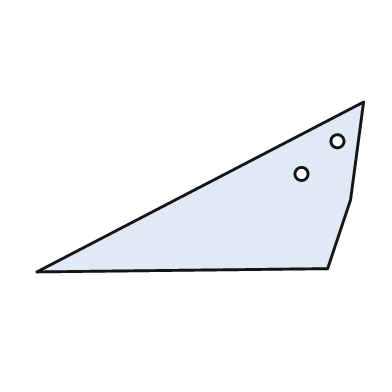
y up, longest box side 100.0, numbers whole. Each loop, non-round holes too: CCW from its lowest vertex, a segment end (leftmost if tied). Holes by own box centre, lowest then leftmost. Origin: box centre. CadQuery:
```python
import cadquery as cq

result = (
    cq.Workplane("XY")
    .moveTo(-50.0, -26.0)
    .lineTo(39.0, -25.0)
    .lineTo(46.0, -4.0)
    .lineTo(50.0, 26.0)
    .close()
    .moveTo(31.0, 4.0)
    .circle(2.0)
    .moveTo(42.0, 14.0)
    .circle(2.0)
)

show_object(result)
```